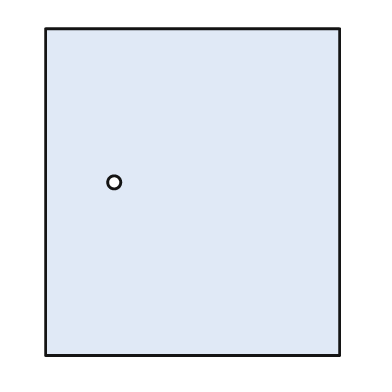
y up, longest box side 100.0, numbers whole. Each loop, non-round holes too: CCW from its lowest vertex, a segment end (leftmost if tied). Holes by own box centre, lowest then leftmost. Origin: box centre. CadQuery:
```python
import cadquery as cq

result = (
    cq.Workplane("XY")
    .moveTo(-45.0, -50.0)
    .lineTo(45.0, -50.0)
    .lineTo(45.0, 50.0)
    .lineTo(-45.0, 50.0)
    .close()
    .moveTo(-24.0, 3.0)
    .circle(2.0)
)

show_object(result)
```